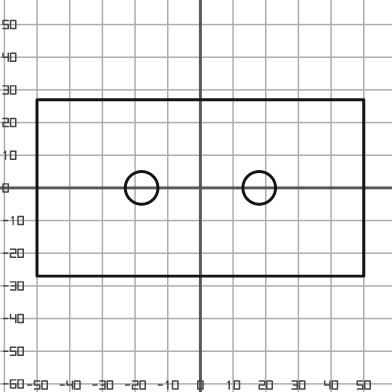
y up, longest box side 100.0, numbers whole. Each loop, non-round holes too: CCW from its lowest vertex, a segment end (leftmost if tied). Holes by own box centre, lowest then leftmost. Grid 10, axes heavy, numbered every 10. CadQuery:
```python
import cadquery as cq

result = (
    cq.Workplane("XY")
    .moveTo(-50.0, -27.0)
    .lineTo(50.0, -27.0)
    .lineTo(50.0, 27.0)
    .lineTo(-50.0, 27.0)
    .close()
    .moveTo(-18.0, 0.0)
    .circle(5.0)
    .moveTo(18.0, 0.0)
    .circle(5.0)
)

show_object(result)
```